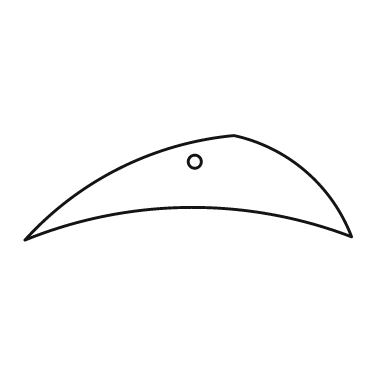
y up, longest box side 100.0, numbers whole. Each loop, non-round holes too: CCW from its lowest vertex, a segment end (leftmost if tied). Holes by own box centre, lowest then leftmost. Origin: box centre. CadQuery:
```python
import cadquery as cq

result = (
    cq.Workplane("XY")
    .moveTo(-50.0, -16.0)
    .threePointArc((0.0, -6.0), (50.0, -15.0))
    .threePointArc((36.0, 5.0), (14.0, 16.0))
    .threePointArc((-21.0, 6.0), (-50.0, -16.0))
    .close()
    .moveTo(2.0, 8.0)
    .circle(2.0)
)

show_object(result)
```